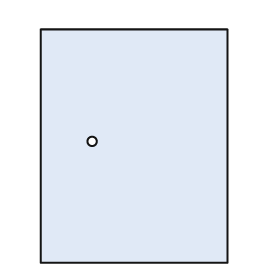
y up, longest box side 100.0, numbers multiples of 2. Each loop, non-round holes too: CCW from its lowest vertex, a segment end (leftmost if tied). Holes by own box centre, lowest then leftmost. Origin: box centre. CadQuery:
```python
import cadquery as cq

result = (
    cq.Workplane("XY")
    .moveTo(-40.0, -50.0)
    .lineTo(40.0, -50.0)
    .lineTo(40.0, 50.0)
    .lineTo(-40.0, 50.0)
    .close()
    .moveTo(-18.0, 2.0)
    .circle(2.0)
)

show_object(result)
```